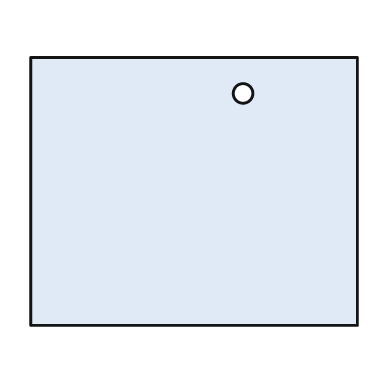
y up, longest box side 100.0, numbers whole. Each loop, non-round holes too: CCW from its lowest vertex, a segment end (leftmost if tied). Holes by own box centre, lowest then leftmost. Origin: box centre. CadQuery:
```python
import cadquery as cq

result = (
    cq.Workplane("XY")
    .moveTo(-50.0, -41.0)
    .lineTo(50.0, -41.0)
    .lineTo(50.0, 41.0)
    .lineTo(-50.0, 41.0)
    .close()
    .moveTo(15.0, 30.0)
    .circle(3.0)
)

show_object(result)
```